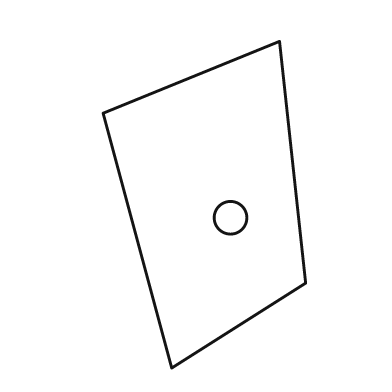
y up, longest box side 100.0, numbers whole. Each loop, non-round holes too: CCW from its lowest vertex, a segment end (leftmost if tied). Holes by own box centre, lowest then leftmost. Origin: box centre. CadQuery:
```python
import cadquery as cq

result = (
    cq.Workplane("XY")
    .moveTo(-10.0, -50.0)
    .lineTo(31.0, -24.0)
    .lineTo(23.0, 50.0)
    .lineTo(-31.0, 28.0)
    .close()
    .moveTo(8.0, -4.0)
    .circle(5.0)
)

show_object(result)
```